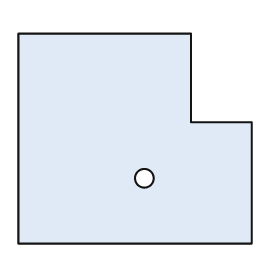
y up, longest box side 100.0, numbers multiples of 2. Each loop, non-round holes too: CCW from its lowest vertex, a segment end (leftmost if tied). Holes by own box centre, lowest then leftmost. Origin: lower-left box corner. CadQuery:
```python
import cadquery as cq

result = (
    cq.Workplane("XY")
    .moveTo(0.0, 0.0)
    .lineTo(100.0, 0.0)
    .lineTo(100.0, 52.0)
    .lineTo(74.0, 52.0)
    .lineTo(74.0, 90.0)
    .lineTo(0.0, 90.0)
    .close()
    .moveTo(54.0, 28.0)
    .circle(4.0)
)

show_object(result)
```